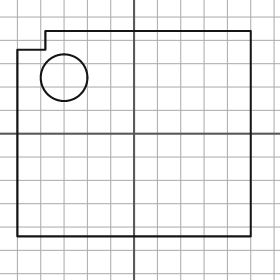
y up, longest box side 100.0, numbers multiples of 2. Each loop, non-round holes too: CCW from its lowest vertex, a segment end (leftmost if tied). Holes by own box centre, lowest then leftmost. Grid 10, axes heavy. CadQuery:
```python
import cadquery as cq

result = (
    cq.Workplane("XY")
    .moveTo(-50.0, -44.0)
    .lineTo(50.0, -44.0)
    .lineTo(50.0, 44.0)
    .lineTo(-38.0, 44.0)
    .lineTo(-38.0, 36.0)
    .lineTo(-50.0, 36.0)
    .close()
    .moveTo(-30.0, 24.0)
    .circle(10.0)
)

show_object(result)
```